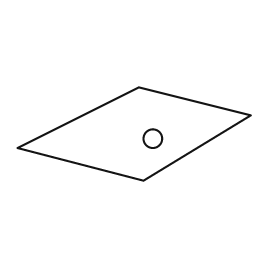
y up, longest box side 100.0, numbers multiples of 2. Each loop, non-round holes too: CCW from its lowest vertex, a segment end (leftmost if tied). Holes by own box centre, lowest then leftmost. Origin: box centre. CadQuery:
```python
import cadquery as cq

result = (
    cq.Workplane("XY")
    .moveTo(4.0, -20.0)
    .lineTo(50.0, 8.0)
    .lineTo(2.0, 20.0)
    .lineTo(-50.0, -6.0)
    .close()
    .moveTo(8.0, -2.0)
    .circle(4.0)
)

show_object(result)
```